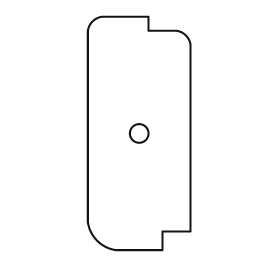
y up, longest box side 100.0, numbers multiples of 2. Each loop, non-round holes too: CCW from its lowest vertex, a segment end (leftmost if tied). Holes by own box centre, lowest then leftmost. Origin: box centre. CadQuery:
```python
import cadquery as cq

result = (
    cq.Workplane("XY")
    .moveTo(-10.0, -50.0)
    .lineTo(10.0, -50.0)
    .lineTo(10.0, -42.0)
    .lineTo(22.0, -42.0)
    .lineTo(22.0, 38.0)
    .threePointArc((20.0, 42.0), (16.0, 44.0))
    .lineTo(4.0, 44.0)
    .lineTo(4.0, 50.0)
    .lineTo(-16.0, 50.0)
    .threePointArc((-20.0, 48.0), (-22.0, 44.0))
    .lineTo(-22.0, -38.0)
    .threePointArc((-18.0, -46.0), (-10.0, -50.0))
    .close()
    .moveTo(0.0, 0.0)
    .circle(4.0)
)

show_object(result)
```